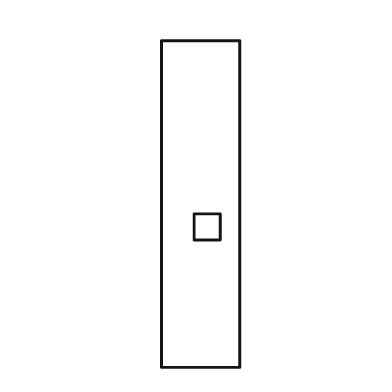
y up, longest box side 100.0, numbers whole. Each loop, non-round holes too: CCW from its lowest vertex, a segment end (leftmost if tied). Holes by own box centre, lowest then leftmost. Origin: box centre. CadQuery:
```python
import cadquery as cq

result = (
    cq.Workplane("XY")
    .moveTo(-12.0, -50.0)
    .lineTo(12.0, -50.0)
    .lineTo(12.0, 50.0)
    .lineTo(-12.0, 50.0)
    .close()
    .moveTo(-2.0, -11.0)
    .lineTo(6.0, -11.0)
    .lineTo(6.0, -3.0)
    .lineTo(-2.0, -3.0)
    .close()
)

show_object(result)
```